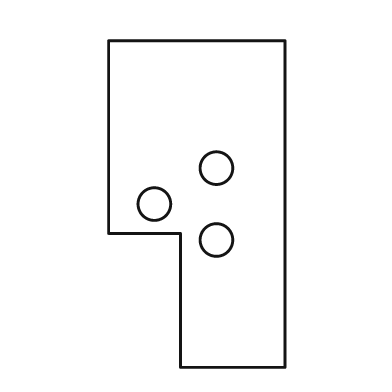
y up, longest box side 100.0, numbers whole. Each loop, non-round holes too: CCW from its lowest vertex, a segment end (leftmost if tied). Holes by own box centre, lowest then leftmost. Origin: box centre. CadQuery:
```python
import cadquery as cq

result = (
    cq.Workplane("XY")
    .moveTo(-5.0, -50.0)
    .lineTo(27.0, -50.0)
    .lineTo(27.0, 50.0)
    .lineTo(-27.0, 50.0)
    .lineTo(-27.0, -9.0)
    .lineTo(-5.0, -9.0)
    .close()
    .moveTo(6.0, -11.0)
    .circle(5.0)
    .moveTo(-13.0, 0.0)
    .circle(5.0)
    .moveTo(6.0, 11.0)
    .circle(5.0)
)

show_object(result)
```